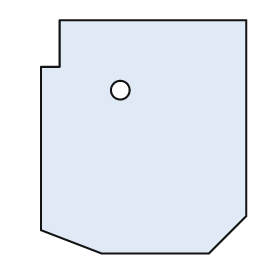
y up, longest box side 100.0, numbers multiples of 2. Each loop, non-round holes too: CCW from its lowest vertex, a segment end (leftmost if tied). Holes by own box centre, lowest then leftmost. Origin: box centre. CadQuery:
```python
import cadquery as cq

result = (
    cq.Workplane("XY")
    .moveTo(-18.0, -50.0)
    .lineTo(28.0, -50.0)
    .lineTo(44.0, -34.0)
    .lineTo(44.0, 50.0)
    .lineTo(-36.0, 50.0)
    .lineTo(-36.0, 30.0)
    .lineTo(-44.0, 30.0)
    .lineTo(-44.0, -40.0)
    .close()
    .moveTo(-10.0, 20.0)
    .circle(4.0)
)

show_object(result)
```